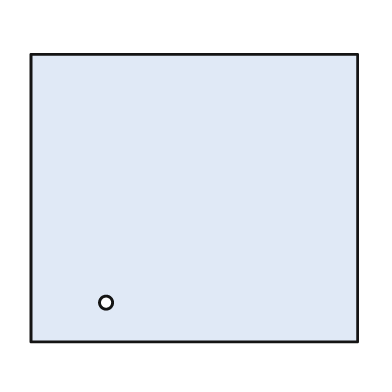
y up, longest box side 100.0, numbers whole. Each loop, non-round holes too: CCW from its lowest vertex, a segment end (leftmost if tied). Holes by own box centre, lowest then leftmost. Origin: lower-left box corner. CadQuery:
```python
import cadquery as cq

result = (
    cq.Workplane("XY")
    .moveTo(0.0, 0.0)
    .lineTo(100.0, 0.0)
    .lineTo(100.0, 88.0)
    .lineTo(0.0, 88.0)
    .close()
    .moveTo(23.0, 12.0)
    .circle(2.0)
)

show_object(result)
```